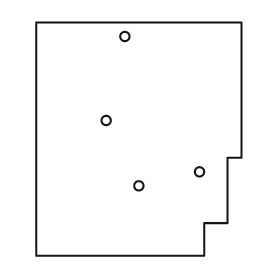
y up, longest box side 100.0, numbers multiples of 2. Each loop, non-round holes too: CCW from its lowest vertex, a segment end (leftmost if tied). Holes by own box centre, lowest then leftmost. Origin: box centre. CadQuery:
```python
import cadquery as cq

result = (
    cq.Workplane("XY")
    .moveTo(-44.0, -50.0)
    .lineTo(28.0, -50.0)
    .lineTo(28.0, -36.0)
    .lineTo(38.0, -36.0)
    .lineTo(38.0, -8.0)
    .lineTo(44.0, -8.0)
    .lineTo(44.0, 50.0)
    .lineTo(-44.0, 50.0)
    .close()
    .moveTo(0.0, -20.0)
    .circle(2.0)
    .moveTo(26.0, -14.0)
    .circle(2.0)
    .moveTo(-14.0, 8.0)
    .circle(2.0)
    .moveTo(-6.0, 44.0)
    .circle(2.0)
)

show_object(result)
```